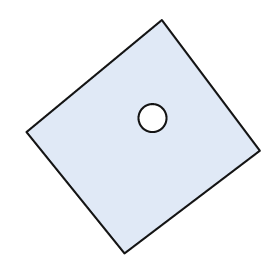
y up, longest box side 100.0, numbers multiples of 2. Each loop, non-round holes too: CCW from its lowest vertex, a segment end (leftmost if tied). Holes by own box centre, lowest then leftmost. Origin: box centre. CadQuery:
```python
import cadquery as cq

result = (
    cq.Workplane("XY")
    .moveTo(-8.0, -50.0)
    .lineTo(50.0, -6.0)
    .lineTo(8.0, 50.0)
    .lineTo(-50.0, 2.0)
    .close()
    .moveTo(4.0, 8.0)
    .circle(6.0)
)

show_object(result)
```